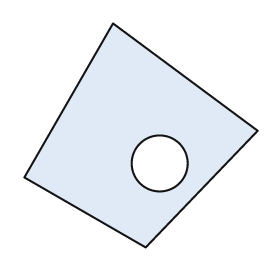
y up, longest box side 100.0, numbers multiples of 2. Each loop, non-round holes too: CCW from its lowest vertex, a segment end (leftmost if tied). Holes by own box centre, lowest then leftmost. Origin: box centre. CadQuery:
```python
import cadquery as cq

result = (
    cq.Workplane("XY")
    .moveTo(2.0, -48.0)
    .lineTo(50.0, 2.0)
    .lineTo(-12.0, 48.0)
    .lineTo(-50.0, -18.0)
    .close()
    .moveTo(8.0, -12.0)
    .circle(12.0)
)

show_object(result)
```